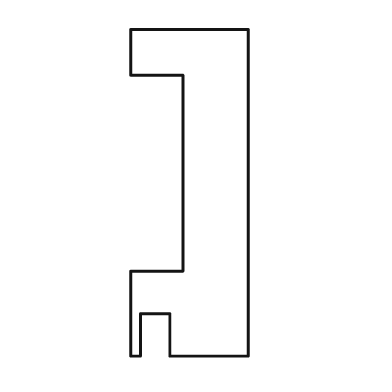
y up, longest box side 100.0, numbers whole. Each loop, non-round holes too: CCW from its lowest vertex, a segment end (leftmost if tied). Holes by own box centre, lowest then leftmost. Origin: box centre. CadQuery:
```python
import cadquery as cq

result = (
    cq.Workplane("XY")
    .moveTo(-18.0, -50.0)
    .lineTo(-15.0, -50.0)
    .lineTo(-15.0, -37.0)
    .lineTo(-6.0, -37.0)
    .lineTo(-6.0, -50.0)
    .lineTo(18.0, -50.0)
    .lineTo(18.0, 50.0)
    .lineTo(-18.0, 50.0)
    .lineTo(-18.0, 36.0)
    .lineTo(-2.0, 36.0)
    .lineTo(-2.0, -24.0)
    .lineTo(-18.0, -24.0)
    .close()
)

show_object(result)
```